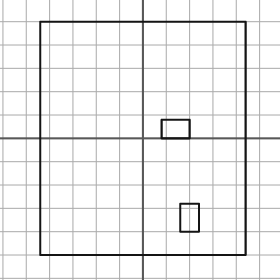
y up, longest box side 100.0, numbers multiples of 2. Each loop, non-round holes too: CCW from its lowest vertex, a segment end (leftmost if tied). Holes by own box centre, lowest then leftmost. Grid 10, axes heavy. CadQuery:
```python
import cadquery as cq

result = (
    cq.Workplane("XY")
    .moveTo(-44.0, -50.0)
    .lineTo(44.0, -50.0)
    .lineTo(44.0, 50.0)
    .lineTo(-44.0, 50.0)
    .close()
    .moveTo(16.0, -40.0)
    .lineTo(24.0, -40.0)
    .lineTo(24.0, -28.0)
    .lineTo(16.0, -28.0)
    .close()
    .moveTo(8.0, 0.0)
    .lineTo(20.0, 0.0)
    .lineTo(20.0, 8.0)
    .lineTo(8.0, 8.0)
    .close()
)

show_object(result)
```